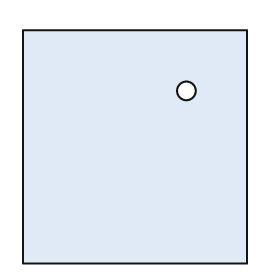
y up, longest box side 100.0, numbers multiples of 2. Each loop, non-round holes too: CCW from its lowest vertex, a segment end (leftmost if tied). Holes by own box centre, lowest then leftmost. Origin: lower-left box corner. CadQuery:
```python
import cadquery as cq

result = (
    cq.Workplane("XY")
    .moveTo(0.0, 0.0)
    .lineTo(96.0, 0.0)
    .lineTo(96.0, 100.0)
    .lineTo(0.0, 100.0)
    .close()
    .moveTo(70.0, 74.0)
    .circle(4.0)
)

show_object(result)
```